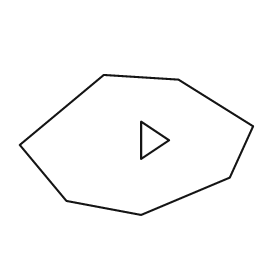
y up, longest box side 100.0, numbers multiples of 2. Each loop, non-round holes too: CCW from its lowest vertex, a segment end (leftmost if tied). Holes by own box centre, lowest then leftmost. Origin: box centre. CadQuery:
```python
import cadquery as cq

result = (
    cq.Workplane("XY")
    .moveTo(2.0, -30.0)
    .lineTo(40.0, -14.0)
    .lineTo(50.0, 8.0)
    .lineTo(18.0, 28.0)
    .lineTo(-14.0, 30.0)
    .lineTo(-50.0, 0.0)
    .lineTo(-30.0, -24.0)
    .close()
    .moveTo(2.0, -6.0)
    .lineTo(14.0, 2.0)
    .lineTo(2.0, 10.0)
    .close()
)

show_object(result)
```